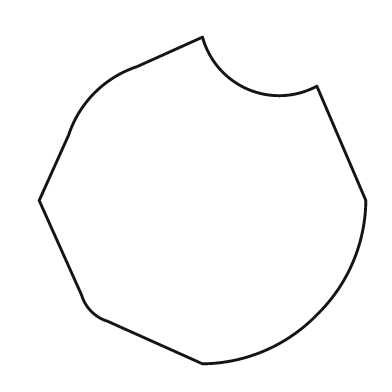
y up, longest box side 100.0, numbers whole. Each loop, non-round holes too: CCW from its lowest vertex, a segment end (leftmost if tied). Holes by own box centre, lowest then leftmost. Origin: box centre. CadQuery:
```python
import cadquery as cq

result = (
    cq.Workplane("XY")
    .moveTo(0.0, -50.0)
    .threePointArc((19.0, -46.0), (35.0, -35.0))
    .threePointArc((46.0, -19.0), (50.0, 0.0))
    .lineTo(35.0, 35.0)
    .threePointArc((14.0, 34.0), (0.0, 50.0))
    .lineTo(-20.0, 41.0)
    .threePointArc((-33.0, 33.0), (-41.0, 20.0))
    .lineTo(-50.0, 0.0)
    .lineTo(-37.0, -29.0)
    .threePointArc((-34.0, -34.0), (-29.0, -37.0))
    .close()
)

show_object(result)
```